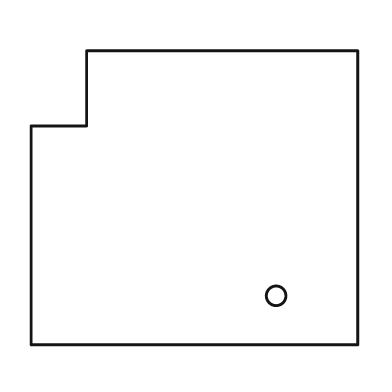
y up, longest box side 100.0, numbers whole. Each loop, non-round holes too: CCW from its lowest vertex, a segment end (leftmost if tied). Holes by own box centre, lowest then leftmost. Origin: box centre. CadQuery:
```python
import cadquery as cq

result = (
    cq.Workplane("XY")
    .moveTo(-50.0, -45.0)
    .lineTo(50.0, -45.0)
    .lineTo(50.0, 45.0)
    .lineTo(-33.0, 45.0)
    .lineTo(-33.0, 22.0)
    .lineTo(-50.0, 22.0)
    .close()
    .moveTo(25.0, -30.0)
    .circle(3.0)
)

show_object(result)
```